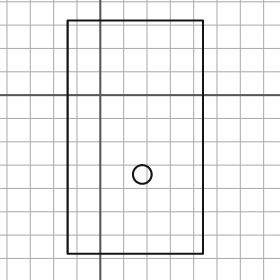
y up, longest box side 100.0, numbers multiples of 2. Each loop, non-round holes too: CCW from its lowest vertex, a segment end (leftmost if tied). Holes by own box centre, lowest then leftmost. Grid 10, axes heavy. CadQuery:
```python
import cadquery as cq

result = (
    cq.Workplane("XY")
    .moveTo(-14.0, -68.0)
    .lineTo(44.0, -68.0)
    .lineTo(44.0, 32.0)
    .lineTo(-14.0, 32.0)
    .close()
    .moveTo(18.0, -34.0)
    .circle(4.0)
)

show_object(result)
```